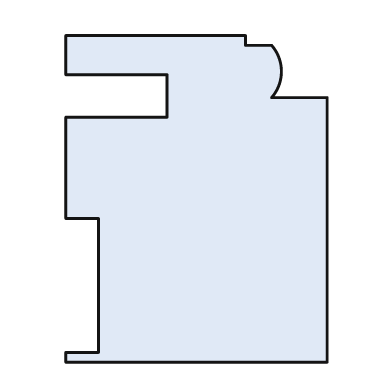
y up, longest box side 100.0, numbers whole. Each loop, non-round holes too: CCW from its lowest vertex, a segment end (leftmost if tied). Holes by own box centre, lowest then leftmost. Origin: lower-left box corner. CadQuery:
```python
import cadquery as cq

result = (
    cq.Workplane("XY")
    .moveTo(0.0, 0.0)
    .lineTo(80.0, 0.0)
    .lineTo(80.0, 81.0)
    .lineTo(63.0, 81.0)
    .threePointArc((66.0, 89.0), (63.0, 97.0))
    .lineTo(55.0, 97.0)
    .lineTo(55.0, 100.0)
    .lineTo(0.0, 100.0)
    .lineTo(0.0, 88.0)
    .lineTo(31.0, 88.0)
    .lineTo(31.0, 75.0)
    .lineTo(0.0, 75.0)
    .lineTo(0.0, 44.0)
    .lineTo(10.0, 44.0)
    .lineTo(10.0, 3.0)
    .lineTo(0.0, 3.0)
    .close()
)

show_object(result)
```